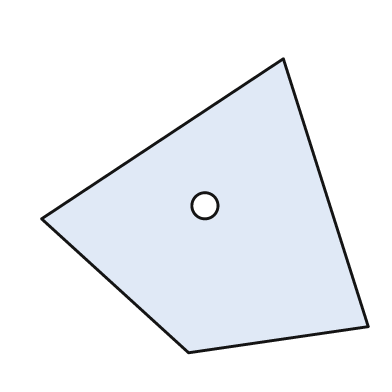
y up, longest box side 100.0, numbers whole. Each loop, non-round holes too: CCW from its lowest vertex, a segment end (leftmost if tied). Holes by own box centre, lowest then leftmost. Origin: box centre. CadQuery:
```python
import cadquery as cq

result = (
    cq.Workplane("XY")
    .moveTo(-5.0, -45.0)
    .lineTo(50.0, -37.0)
    .lineTo(24.0, 45.0)
    .lineTo(-50.0, -4.0)
    .close()
    .moveTo(0.0, 0.0)
    .circle(4.0)
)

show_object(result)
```